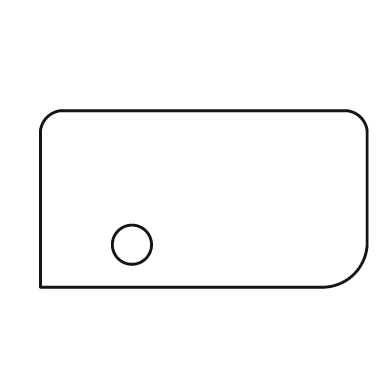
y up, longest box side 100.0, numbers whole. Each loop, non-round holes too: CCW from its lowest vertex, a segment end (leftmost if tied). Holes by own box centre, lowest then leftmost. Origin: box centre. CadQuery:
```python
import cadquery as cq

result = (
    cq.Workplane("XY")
    .moveTo(-50.0, -27.0)
    .lineTo(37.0, -27.0)
    .threePointArc((46.0, -23.0), (50.0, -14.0))
    .lineTo(50.0, 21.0)
    .threePointArc((48.0, 25.0), (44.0, 27.0))
    .lineTo(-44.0, 27.0)
    .threePointArc((-48.0, 25.0), (-50.0, 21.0))
    .close()
    .moveTo(-22.0, -14.0)
    .circle(6.0)
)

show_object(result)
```